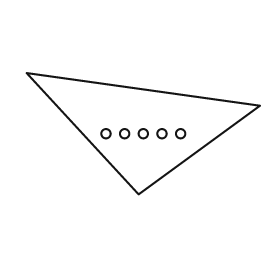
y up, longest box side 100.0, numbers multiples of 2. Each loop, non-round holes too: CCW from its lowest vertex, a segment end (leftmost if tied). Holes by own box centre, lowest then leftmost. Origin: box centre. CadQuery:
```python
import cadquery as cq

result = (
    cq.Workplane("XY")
    .moveTo(-2.0, -26.0)
    .lineTo(50.0, 12.0)
    .lineTo(-50.0, 26.0)
    .close()
    .moveTo(-16.0, 0.0)
    .circle(2.0)
    .moveTo(-8.0, 0.0)
    .circle(2.0)
    .moveTo(0.0, 0.0)
    .circle(2.0)
    .moveTo(8.0, 0.0)
    .circle(2.0)
    .moveTo(16.0, 0.0)
    .circle(2.0)
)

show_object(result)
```